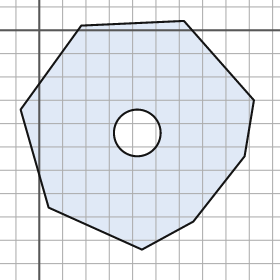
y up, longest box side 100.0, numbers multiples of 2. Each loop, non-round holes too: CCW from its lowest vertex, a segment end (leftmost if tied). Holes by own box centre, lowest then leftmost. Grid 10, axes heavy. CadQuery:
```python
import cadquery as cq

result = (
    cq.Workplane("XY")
    .moveTo(44.0, -94.0)
    .lineTo(66.0, -82.0)
    .lineTo(88.0, -54.0)
    .lineTo(92.0, -30.0)
    .lineTo(62.0, 4.0)
    .lineTo(18.0, 2.0)
    .lineTo(-8.0, -34.0)
    .lineTo(4.0, -76.0)
    .close()
    .moveTo(42.0, -44.0)
    .circle(10.0)
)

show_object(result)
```